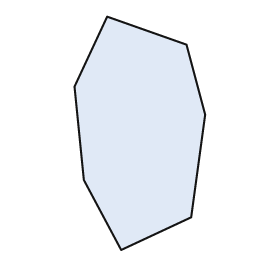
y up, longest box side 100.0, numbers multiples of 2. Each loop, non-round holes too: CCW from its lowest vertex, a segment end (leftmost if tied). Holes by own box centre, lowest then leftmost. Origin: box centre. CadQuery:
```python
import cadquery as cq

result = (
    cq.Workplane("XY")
    .moveTo(-8.0, -50.0)
    .lineTo(22.0, -36.0)
    .lineTo(28.0, 8.0)
    .lineTo(20.0, 38.0)
    .lineTo(-14.0, 50.0)
    .lineTo(-28.0, 20.0)
    .lineTo(-24.0, -20.0)
    .close()
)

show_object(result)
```